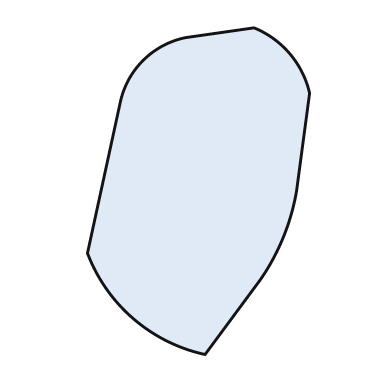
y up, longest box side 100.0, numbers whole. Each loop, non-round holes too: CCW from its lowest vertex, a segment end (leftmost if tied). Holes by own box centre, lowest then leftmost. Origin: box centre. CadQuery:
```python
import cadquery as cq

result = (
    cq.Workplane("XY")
    .moveTo(2.0, -50.0)
    .lineTo(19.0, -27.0)
    .threePointArc((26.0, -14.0), (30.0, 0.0))
    .lineTo(34.0, 30.0)
    .threePointArc((28.0, 42.0), (17.0, 50.0))
    .lineTo(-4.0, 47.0)
    .threePointArc((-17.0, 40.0), (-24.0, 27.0))
    .lineTo(-34.0, -19.0)
    .threePointArc((-20.0, -39.0), (2.0, -50.0))
    .close()
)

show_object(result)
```